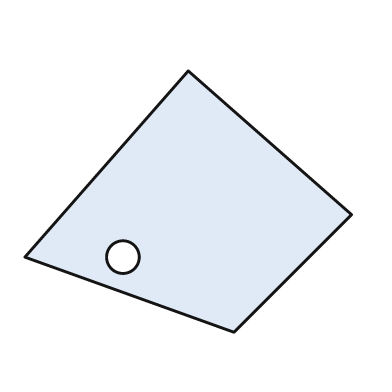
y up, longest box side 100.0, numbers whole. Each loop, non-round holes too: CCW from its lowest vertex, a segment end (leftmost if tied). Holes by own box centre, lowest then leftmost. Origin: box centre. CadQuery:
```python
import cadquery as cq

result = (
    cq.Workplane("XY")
    .moveTo(14.0, -40.0)
    .lineTo(50.0, -4.0)
    .lineTo(0.0, 40.0)
    .lineTo(-50.0, -17.0)
    .close()
    .moveTo(-20.0, -17.0)
    .circle(5.0)
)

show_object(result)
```